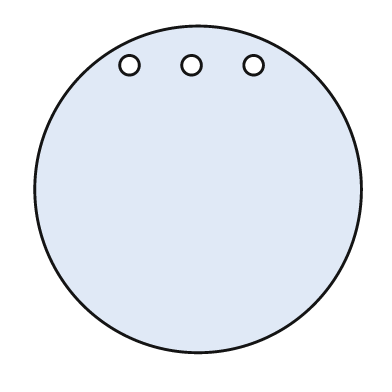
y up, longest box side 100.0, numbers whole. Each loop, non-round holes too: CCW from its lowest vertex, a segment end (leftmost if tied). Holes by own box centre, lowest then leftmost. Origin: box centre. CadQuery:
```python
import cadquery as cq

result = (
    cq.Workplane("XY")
    .moveTo(0.0, 0.0)
    .circle(50.0)
    .moveTo(-21.0, 38.0)
    .circle(3.0)
    .moveTo(-2.0, 38.0)
    .circle(3.0)
    .moveTo(17.0, 38.0)
    .circle(3.0)
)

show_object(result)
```